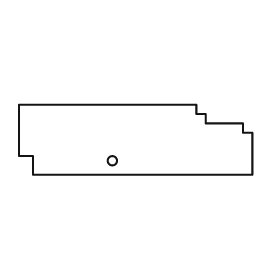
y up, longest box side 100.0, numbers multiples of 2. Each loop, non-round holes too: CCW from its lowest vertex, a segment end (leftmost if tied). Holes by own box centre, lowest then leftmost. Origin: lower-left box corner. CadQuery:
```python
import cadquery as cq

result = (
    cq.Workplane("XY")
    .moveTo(6.0, 0.0)
    .lineTo(100.0, 0.0)
    .lineTo(100.0, 18.0)
    .lineTo(96.0, 18.0)
    .lineTo(96.0, 22.0)
    .lineTo(80.0, 22.0)
    .lineTo(80.0, 26.0)
    .lineTo(76.0, 26.0)
    .lineTo(76.0, 30.0)
    .lineTo(0.0, 30.0)
    .lineTo(0.0, 8.0)
    .lineTo(6.0, 8.0)
    .close()
    .moveTo(40.0, 6.0)
    .circle(2.0)
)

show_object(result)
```